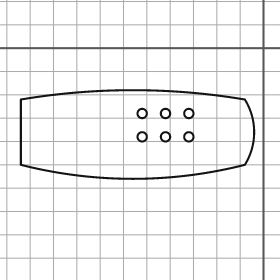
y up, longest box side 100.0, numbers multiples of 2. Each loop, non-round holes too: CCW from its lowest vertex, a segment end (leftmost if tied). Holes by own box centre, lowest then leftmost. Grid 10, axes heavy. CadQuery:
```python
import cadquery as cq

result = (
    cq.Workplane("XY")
    .moveTo(-104.0, -50.0)
    .threePointArc((-56.0, -56.0), (-8.0, -50.0))
    .threePointArc((-4.0, -36.0), (-8.0, -22.0))
    .threePointArc((-56.0, -18.0), (-104.0, -22.0))
    .close()
    .moveTo(-52.0, -38.0)
    .circle(2.0)
    .moveTo(-42.0, -38.0)
    .circle(2.0)
    .moveTo(-32.0, -38.0)
    .circle(2.0)
    .moveTo(-52.0, -28.0)
    .circle(2.0)
    .moveTo(-42.0, -28.0)
    .circle(2.0)
    .moveTo(-32.0, -28.0)
    .circle(2.0)
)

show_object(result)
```